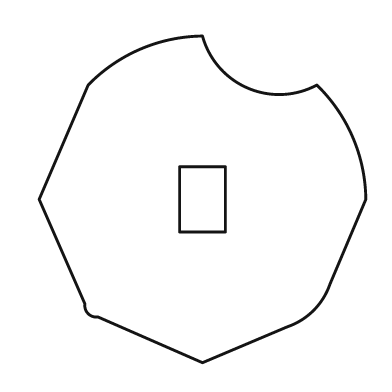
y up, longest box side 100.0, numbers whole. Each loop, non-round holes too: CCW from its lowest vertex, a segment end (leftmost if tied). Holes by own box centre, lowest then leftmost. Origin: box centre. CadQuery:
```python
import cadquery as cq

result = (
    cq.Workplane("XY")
    .moveTo(0.0, -50.0)
    .lineTo(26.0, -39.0)
    .threePointArc((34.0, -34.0), (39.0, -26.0))
    .lineTo(50.0, 0.0)
    .threePointArc((46.0, 19.0), (35.0, 35.0))
    .threePointArc((14.0, 34.0), (0.0, 50.0))
    .threePointArc((-19.0, 46.0), (-35.0, 35.0))
    .lineTo(-50.0, 0.0)
    .lineTo(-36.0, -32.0)
    .threePointArc((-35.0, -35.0), (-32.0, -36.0))
    .close()
    .moveTo(-7.0, -10.0)
    .lineTo(7.0, -10.0)
    .lineTo(7.0, 10.0)
    .lineTo(-7.0, 10.0)
    .close()
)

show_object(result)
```